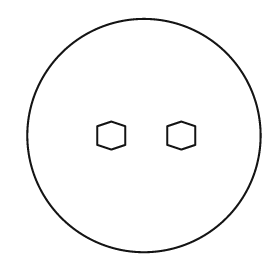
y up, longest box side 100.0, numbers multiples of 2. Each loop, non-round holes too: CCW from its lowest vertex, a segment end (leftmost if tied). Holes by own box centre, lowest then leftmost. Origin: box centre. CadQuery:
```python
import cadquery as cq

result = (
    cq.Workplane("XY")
    .moveTo(0.0, 0.0)
    .circle(50.0)
    .moveTo(-14.0, -6.0)
    .lineTo(-8.0, -4.0)
    .lineTo(-8.0, 4.0)
    .lineTo(-14.0, 6.0)
    .lineTo(-20.0, 4.0)
    .lineTo(-20.0, -4.0)
    .close()
    .moveTo(16.0, -6.0)
    .lineTo(22.0, -4.0)
    .lineTo(22.0, 4.0)
    .lineTo(16.0, 6.0)
    .lineTo(10.0, 4.0)
    .lineTo(10.0, -4.0)
    .close()
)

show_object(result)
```